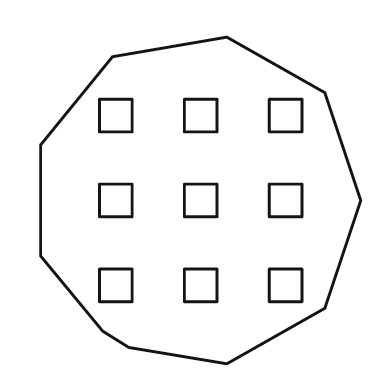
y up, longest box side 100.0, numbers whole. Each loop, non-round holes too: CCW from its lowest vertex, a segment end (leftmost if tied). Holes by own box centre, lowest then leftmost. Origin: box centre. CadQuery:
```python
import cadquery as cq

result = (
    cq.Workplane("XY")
    .moveTo(8.0, -50.0)
    .lineTo(38.0, -33.0)
    .lineTo(49.0, 0.0)
    .lineTo(38.0, 33.0)
    .lineTo(8.0, 50.0)
    .lineTo(-27.0, 44.0)
    .lineTo(-49.0, 17.0)
    .lineTo(-49.0, -17.0)
    .lineTo(-30.0, -40.0)
    .lineTo(-22.0, -45.0)
    .close()
    .moveTo(-31.0, -31.0)
    .lineTo(-21.0, -31.0)
    .lineTo(-21.0, -21.0)
    .lineTo(-31.0, -21.0)
    .close()
    .moveTo(-5.0, -31.0)
    .lineTo(5.0, -31.0)
    .lineTo(5.0, -21.0)
    .lineTo(-5.0, -21.0)
    .close()
    .moveTo(21.0, -31.0)
    .lineTo(31.0, -31.0)
    .lineTo(31.0, -21.0)
    .lineTo(21.0, -21.0)
    .close()
    .moveTo(-31.0, -5.0)
    .lineTo(-21.0, -5.0)
    .lineTo(-21.0, 5.0)
    .lineTo(-31.0, 5.0)
    .close()
    .moveTo(-5.0, -5.0)
    .lineTo(5.0, -5.0)
    .lineTo(5.0, 5.0)
    .lineTo(-5.0, 5.0)
    .close()
    .moveTo(21.0, -5.0)
    .lineTo(31.0, -5.0)
    .lineTo(31.0, 5.0)
    .lineTo(21.0, 5.0)
    .close()
    .moveTo(-31.0, 21.0)
    .lineTo(-21.0, 21.0)
    .lineTo(-21.0, 31.0)
    .lineTo(-31.0, 31.0)
    .close()
    .moveTo(-5.0, 21.0)
    .lineTo(5.0, 21.0)
    .lineTo(5.0, 31.0)
    .lineTo(-5.0, 31.0)
    .close()
    .moveTo(21.0, 21.0)
    .lineTo(31.0, 21.0)
    .lineTo(31.0, 31.0)
    .lineTo(21.0, 31.0)
    .close()
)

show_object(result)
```